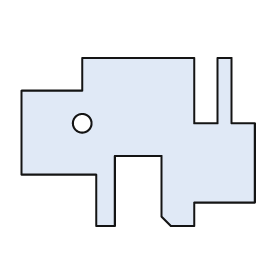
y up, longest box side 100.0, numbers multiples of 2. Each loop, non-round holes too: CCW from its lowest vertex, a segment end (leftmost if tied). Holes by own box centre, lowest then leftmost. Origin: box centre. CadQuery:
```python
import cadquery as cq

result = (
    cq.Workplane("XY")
    .moveTo(-18.0, -36.0)
    .lineTo(-10.0, -36.0)
    .lineTo(-10.0, -6.0)
    .lineTo(10.0, -6.0)
    .lineTo(10.0, -32.0)
    .lineTo(14.0, -36.0)
    .lineTo(24.0, -36.0)
    .lineTo(24.0, -26.0)
    .lineTo(50.0, -26.0)
    .lineTo(50.0, 8.0)
    .lineTo(40.0, 8.0)
    .lineTo(40.0, 36.0)
    .lineTo(34.0, 36.0)
    .lineTo(34.0, 8.0)
    .lineTo(24.0, 8.0)
    .lineTo(24.0, 36.0)
    .lineTo(-24.0, 36.0)
    .lineTo(-24.0, 22.0)
    .lineTo(-50.0, 22.0)
    .lineTo(-50.0, -14.0)
    .lineTo(-18.0, -14.0)
    .close()
    .moveTo(-24.0, 8.0)
    .circle(4.0)
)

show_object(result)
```